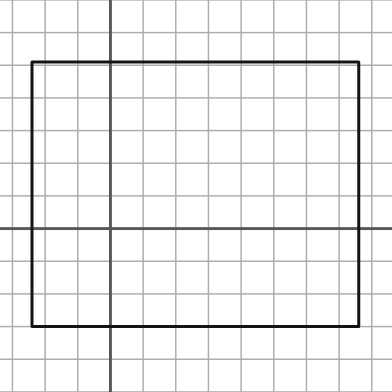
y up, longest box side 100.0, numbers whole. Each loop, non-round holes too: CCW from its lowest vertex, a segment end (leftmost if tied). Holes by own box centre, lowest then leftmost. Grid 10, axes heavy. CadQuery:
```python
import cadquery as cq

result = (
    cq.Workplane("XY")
    .moveTo(-24.0, -30.0)
    .lineTo(76.0, -30.0)
    .lineTo(76.0, 51.0)
    .lineTo(-24.0, 51.0)
    .close()
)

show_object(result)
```